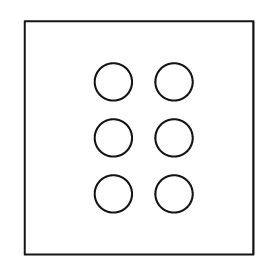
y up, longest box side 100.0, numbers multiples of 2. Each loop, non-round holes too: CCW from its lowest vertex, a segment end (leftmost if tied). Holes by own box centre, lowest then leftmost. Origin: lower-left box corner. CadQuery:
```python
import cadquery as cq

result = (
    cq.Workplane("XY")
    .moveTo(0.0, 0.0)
    .lineTo(98.0, 0.0)
    .lineTo(98.0, 100.0)
    .lineTo(0.0, 100.0)
    .close()
    .moveTo(38.0, 26.0)
    .circle(8.0)
    .moveTo(64.0, 26.0)
    .circle(8.0)
    .moveTo(38.0, 50.0)
    .circle(8.0)
    .moveTo(64.0, 50.0)
    .circle(8.0)
    .moveTo(38.0, 74.0)
    .circle(8.0)
    .moveTo(64.0, 74.0)
    .circle(8.0)
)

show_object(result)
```